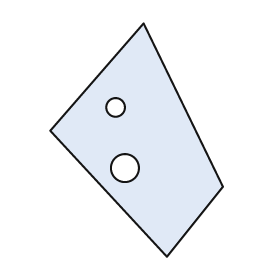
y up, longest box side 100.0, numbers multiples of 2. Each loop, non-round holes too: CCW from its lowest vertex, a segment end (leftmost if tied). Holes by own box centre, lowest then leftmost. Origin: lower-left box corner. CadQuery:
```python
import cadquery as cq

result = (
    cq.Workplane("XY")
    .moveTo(50.0, 0.0)
    .lineTo(74.0, 30.0)
    .lineTo(40.0, 100.0)
    .lineTo(0.0, 54.0)
    .close()
    .moveTo(32.0, 38.0)
    .circle(6.0)
    .moveTo(28.0, 64.0)
    .circle(4.0)
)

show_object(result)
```